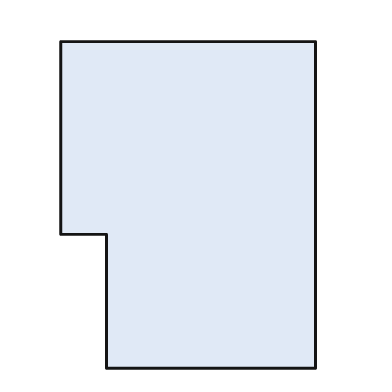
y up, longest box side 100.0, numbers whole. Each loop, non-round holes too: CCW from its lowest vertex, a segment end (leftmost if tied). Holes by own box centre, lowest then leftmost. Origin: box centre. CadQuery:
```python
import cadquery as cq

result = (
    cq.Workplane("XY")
    .moveTo(-25.0, -50.0)
    .lineTo(39.0, -50.0)
    .lineTo(39.0, 50.0)
    .lineTo(-39.0, 50.0)
    .lineTo(-39.0, -9.0)
    .lineTo(-25.0, -9.0)
    .close()
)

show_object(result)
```